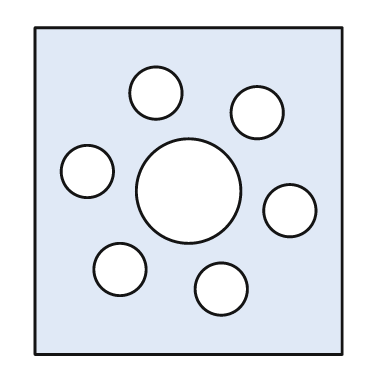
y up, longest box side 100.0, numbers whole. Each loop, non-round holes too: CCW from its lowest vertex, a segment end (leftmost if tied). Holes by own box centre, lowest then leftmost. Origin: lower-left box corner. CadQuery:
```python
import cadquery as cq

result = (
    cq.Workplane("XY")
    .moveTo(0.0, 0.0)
    .lineTo(94.0, 0.0)
    .lineTo(94.0, 100.0)
    .lineTo(0.0, 100.0)
    .close()
    .moveTo(57.0, 20.0)
    .circle(8.0)
    .moveTo(26.0, 26.0)
    .circle(8.0)
    .moveTo(78.0, 44.0)
    .circle(8.0)
    .moveTo(47.0, 50.0)
    .circle(16.0)
    .moveTo(16.0, 56.0)
    .circle(8.0)
    .moveTo(68.0, 74.0)
    .circle(8.0)
    .moveTo(37.0, 80.0)
    .circle(8.0)
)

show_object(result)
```